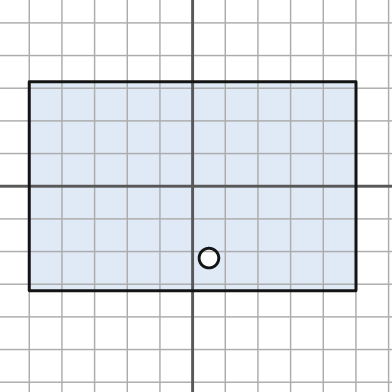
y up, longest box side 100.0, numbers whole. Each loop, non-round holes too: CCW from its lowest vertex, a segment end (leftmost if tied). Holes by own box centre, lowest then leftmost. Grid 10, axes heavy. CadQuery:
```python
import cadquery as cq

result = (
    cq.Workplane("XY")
    .moveTo(-50.0, -32.0)
    .lineTo(50.0, -32.0)
    .lineTo(50.0, 32.0)
    .lineTo(-50.0, 32.0)
    .close()
    .moveTo(5.0, -22.0)
    .circle(3.0)
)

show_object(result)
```